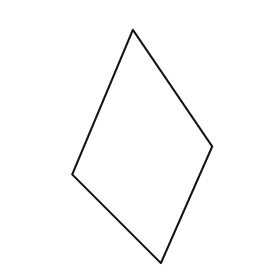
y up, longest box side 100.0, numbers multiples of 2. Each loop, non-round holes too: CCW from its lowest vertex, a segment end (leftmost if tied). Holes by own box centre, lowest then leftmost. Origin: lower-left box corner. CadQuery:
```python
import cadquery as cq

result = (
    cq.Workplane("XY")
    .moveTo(38.0, 0.0)
    .lineTo(60.0, 50.0)
    .lineTo(26.0, 100.0)
    .lineTo(0.0, 38.0)
    .close()
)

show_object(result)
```